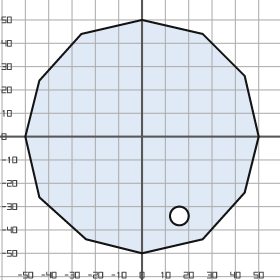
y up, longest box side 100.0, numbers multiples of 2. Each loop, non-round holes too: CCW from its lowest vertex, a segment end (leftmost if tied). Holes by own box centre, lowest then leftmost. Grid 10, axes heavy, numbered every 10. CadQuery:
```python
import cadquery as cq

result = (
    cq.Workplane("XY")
    .moveTo(0.0, -50.0)
    .lineTo(26.0, -44.0)
    .lineTo(44.0, -24.0)
    .lineTo(50.0, 0.0)
    .lineTo(44.0, 26.0)
    .lineTo(26.0, 44.0)
    .lineTo(0.0, 50.0)
    .lineTo(-26.0, 44.0)
    .lineTo(-44.0, 24.0)
    .lineTo(-50.0, 0.0)
    .lineTo(-44.0, -26.0)
    .lineTo(-24.0, -44.0)
    .close()
    .moveTo(16.0, -34.0)
    .circle(4.0)
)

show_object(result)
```